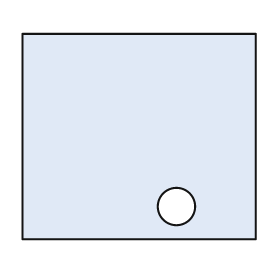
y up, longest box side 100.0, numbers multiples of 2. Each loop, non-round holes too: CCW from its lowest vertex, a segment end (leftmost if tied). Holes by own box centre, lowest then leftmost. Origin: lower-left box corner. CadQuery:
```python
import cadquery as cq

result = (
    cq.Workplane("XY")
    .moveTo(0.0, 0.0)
    .lineTo(100.0, 0.0)
    .lineTo(100.0, 88.0)
    .lineTo(0.0, 88.0)
    .close()
    .moveTo(66.0, 14.0)
    .circle(8.0)
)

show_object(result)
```